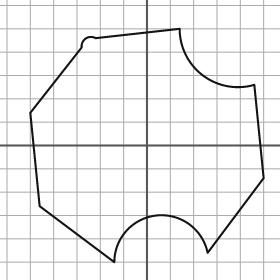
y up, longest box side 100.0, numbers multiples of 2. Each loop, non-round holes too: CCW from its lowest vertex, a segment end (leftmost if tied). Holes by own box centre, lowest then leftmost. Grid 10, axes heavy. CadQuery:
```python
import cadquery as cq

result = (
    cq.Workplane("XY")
    .moveTo(-14.0, -50.0)
    .threePointArc((4.0, -30.0), (26.0, -46.0))
    .lineTo(50.0, -14.0)
    .lineTo(46.0, 26.0)
    .threePointArc((24.0, 30.0), (14.0, 50.0))
    .lineTo(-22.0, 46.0)
    .threePointArc((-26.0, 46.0), (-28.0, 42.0))
    .lineTo(-50.0, 14.0)
    .lineTo(-46.0, -26.0)
    .close()
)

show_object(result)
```